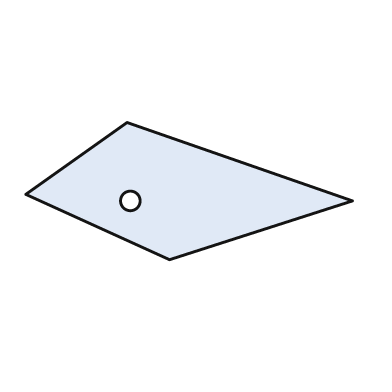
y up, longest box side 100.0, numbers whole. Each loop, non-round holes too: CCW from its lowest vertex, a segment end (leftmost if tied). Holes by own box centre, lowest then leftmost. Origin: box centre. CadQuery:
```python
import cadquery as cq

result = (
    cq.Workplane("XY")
    .moveTo(-6.0, -21.0)
    .lineTo(50.0, -3.0)
    .lineTo(-19.0, 21.0)
    .lineTo(-50.0, -1.0)
    .close()
    .moveTo(-18.0, -3.0)
    .circle(3.0)
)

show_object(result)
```